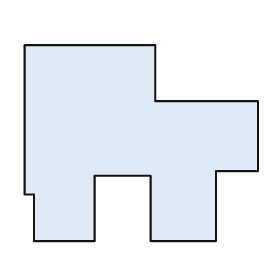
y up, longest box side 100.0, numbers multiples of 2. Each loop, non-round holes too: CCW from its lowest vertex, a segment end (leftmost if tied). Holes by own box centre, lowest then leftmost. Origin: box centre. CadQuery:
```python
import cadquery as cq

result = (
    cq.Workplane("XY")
    .moveTo(-46.0, -42.0)
    .lineTo(-20.0, -42.0)
    .lineTo(-20.0, -14.0)
    .lineTo(4.0, -14.0)
    .lineTo(4.0, -42.0)
    .lineTo(32.0, -42.0)
    .lineTo(32.0, -12.0)
    .lineTo(50.0, -12.0)
    .lineTo(50.0, 18.0)
    .lineTo(6.0, 18.0)
    .lineTo(6.0, 42.0)
    .lineTo(-50.0, 42.0)
    .lineTo(-50.0, -22.0)
    .lineTo(-46.0, -22.0)
    .close()
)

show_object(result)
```